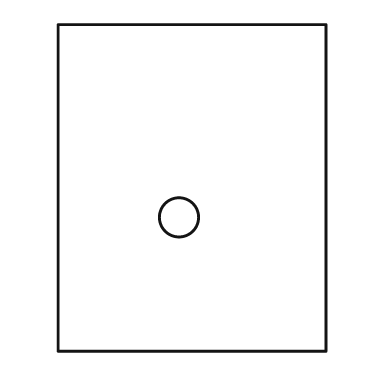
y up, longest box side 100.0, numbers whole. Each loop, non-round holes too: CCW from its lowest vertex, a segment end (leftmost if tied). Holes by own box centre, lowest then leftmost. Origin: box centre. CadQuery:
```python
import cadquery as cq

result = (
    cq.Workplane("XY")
    .moveTo(-41.0, -50.0)
    .lineTo(41.0, -50.0)
    .lineTo(41.0, 50.0)
    .lineTo(-41.0, 50.0)
    .close()
    .moveTo(-4.0, -9.0)
    .circle(6.0)
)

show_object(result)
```